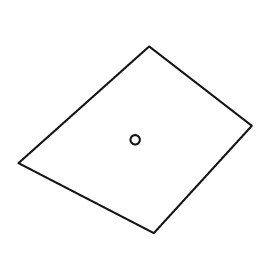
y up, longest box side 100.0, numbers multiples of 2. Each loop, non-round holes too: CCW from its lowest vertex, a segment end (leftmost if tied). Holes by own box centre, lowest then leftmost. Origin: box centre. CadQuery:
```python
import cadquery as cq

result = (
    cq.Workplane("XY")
    .moveTo(8.0, -40.0)
    .lineTo(50.0, 6.0)
    .lineTo(6.0, 40.0)
    .lineTo(-50.0, -10.0)
    .close()
    .moveTo(0.0, 0.0)
    .circle(2.0)
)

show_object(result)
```